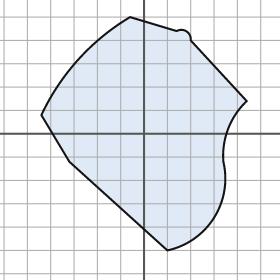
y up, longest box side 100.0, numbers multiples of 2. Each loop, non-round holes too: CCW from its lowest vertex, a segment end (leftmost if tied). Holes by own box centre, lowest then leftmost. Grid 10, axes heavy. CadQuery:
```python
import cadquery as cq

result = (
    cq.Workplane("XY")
    .moveTo(10.0, -50.0)
    .threePointArc((30.0, -36.0), (34.0, -12.0))
    .threePointArc((36.0, 2.0), (44.0, 14.0))
    .lineTo(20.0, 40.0)
    .threePointArc((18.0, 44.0), (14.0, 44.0))
    .lineTo(-6.0, 50.0)
    .threePointArc((-28.0, 32.0), (-44.0, 8.0))
    .lineTo(-32.0, -12.0)
    .close()
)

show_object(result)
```